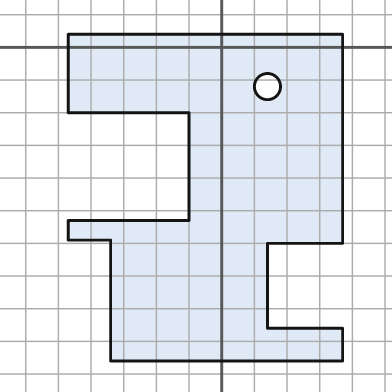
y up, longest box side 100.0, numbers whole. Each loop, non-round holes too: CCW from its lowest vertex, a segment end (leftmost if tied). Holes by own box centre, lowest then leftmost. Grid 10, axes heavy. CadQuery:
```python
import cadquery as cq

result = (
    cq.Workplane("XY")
    .moveTo(-34.0, -96.0)
    .lineTo(37.0, -96.0)
    .lineTo(37.0, -86.0)
    .lineTo(14.0, -86.0)
    .lineTo(14.0, -60.0)
    .lineTo(37.0, -60.0)
    .lineTo(37.0, 4.0)
    .lineTo(-47.0, 4.0)
    .lineTo(-47.0, -20.0)
    .lineTo(-10.0, -20.0)
    .lineTo(-10.0, -53.0)
    .lineTo(-47.0, -53.0)
    .lineTo(-47.0, -59.0)
    .lineTo(-34.0, -59.0)
    .close()
    .moveTo(14.0, -12.0)
    .circle(4.0)
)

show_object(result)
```